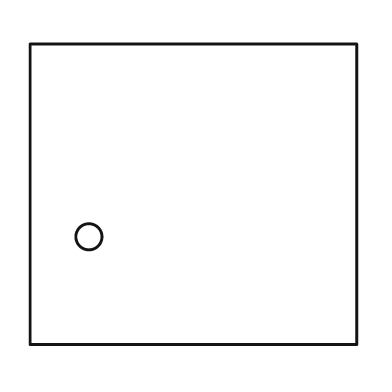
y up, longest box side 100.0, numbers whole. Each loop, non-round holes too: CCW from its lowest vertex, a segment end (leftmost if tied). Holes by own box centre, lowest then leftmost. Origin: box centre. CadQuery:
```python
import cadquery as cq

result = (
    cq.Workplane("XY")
    .moveTo(-50.0, -46.0)
    .lineTo(50.0, -46.0)
    .lineTo(50.0, 46.0)
    .lineTo(-50.0, 46.0)
    .close()
    .moveTo(-32.0, -13.0)
    .circle(4.0)
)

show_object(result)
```